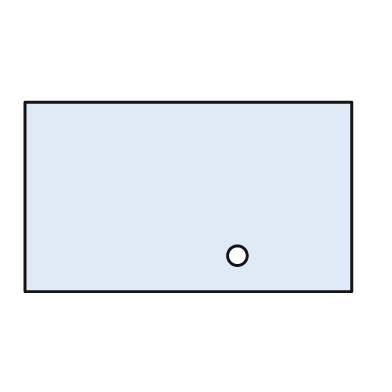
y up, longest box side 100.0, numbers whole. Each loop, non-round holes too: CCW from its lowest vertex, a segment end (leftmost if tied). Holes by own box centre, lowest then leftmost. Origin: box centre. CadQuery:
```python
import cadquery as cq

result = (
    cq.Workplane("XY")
    .moveTo(-50.0, -29.0)
    .lineTo(50.0, -29.0)
    .lineTo(50.0, 29.0)
    .lineTo(-50.0, 29.0)
    .close()
    .moveTo(15.0, -18.0)
    .circle(3.0)
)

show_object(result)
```